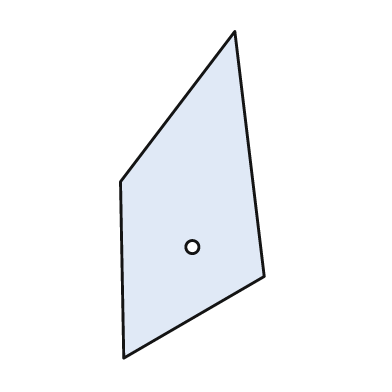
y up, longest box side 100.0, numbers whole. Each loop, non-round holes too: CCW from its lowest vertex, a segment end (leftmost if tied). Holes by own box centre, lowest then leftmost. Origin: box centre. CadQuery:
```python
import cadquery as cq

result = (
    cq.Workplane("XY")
    .moveTo(-21.0, -50.0)
    .lineTo(22.0, -25.0)
    .lineTo(13.0, 50.0)
    .lineTo(-22.0, 4.0)
    .close()
    .moveTo(0.0, -16.0)
    .circle(2.0)
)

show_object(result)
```